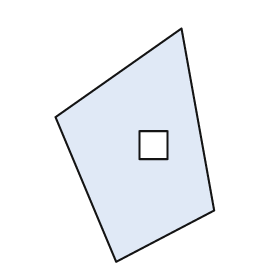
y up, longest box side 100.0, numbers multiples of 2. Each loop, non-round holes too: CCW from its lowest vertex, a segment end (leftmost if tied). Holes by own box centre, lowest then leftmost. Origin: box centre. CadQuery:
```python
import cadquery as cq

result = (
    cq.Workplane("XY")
    .moveTo(-8.0, -50.0)
    .lineTo(34.0, -28.0)
    .lineTo(20.0, 50.0)
    .lineTo(-34.0, 12.0)
    .close()
    .moveTo(2.0, -6.0)
    .lineTo(14.0, -6.0)
    .lineTo(14.0, 6.0)
    .lineTo(2.0, 6.0)
    .close()
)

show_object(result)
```